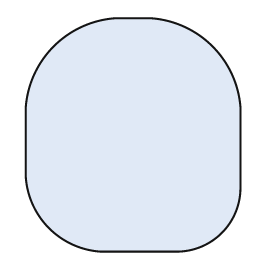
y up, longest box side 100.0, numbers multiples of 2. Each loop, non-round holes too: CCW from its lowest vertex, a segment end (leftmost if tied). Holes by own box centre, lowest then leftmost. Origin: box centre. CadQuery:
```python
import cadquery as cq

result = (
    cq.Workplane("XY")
    .moveTo(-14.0, -50.0)
    .lineTo(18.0, -50.0)
    .threePointArc((38.0, -42.0), (46.0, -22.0))
    .lineTo(46.0, 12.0)
    .threePointArc((34.0, 38.0), (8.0, 50.0))
    .lineTo(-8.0, 50.0)
    .threePointArc((-34.0, 38.0), (-46.0, 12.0))
    .lineTo(-46.0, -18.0)
    .threePointArc((-36.0, -40.0), (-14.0, -50.0))
    .close()
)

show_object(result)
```